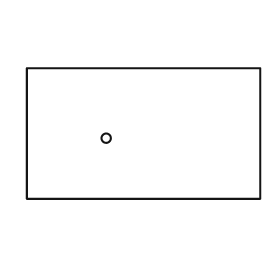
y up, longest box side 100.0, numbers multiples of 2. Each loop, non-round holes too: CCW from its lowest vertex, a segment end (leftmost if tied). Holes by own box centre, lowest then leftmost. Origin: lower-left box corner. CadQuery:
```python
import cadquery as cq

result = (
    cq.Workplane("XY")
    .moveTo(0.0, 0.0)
    .lineTo(100.0, 0.0)
    .lineTo(100.0, 56.0)
    .lineTo(0.0, 56.0)
    .close()
    .moveTo(34.0, 26.0)
    .circle(2.0)
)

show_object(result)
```